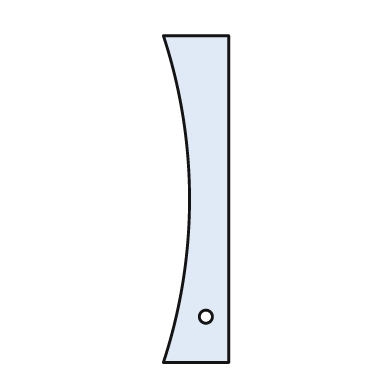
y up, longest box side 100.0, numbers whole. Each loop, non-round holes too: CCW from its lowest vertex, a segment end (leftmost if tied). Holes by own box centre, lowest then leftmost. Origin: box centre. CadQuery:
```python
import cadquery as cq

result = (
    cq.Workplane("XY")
    .moveTo(-10.0, -50.0)
    .lineTo(10.0, -50.0)
    .lineTo(10.0, 50.0)
    .lineTo(-10.0, 50.0)
    .threePointArc((-2.0, 0.0), (-10.0, -50.0))
    .close()
    .moveTo(3.0, -36.0)
    .circle(2.0)
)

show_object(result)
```